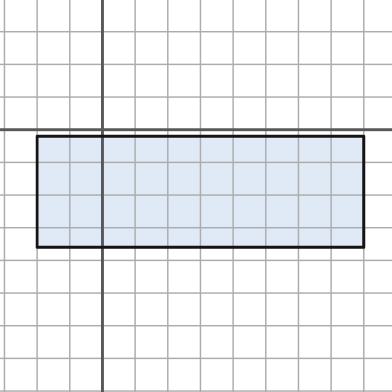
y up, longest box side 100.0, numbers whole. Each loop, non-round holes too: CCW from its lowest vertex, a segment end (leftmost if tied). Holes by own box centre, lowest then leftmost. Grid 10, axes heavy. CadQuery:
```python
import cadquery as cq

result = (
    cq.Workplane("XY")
    .moveTo(-20.0, -36.0)
    .lineTo(80.0, -36.0)
    .lineTo(80.0, -2.0)
    .lineTo(-20.0, -2.0)
    .close()
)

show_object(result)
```